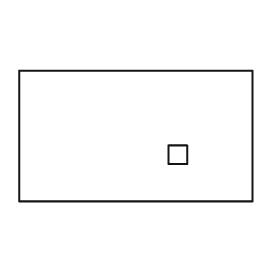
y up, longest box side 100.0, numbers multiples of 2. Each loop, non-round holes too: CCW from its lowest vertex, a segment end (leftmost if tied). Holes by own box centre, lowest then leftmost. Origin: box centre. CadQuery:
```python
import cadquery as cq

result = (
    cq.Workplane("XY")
    .moveTo(-50.0, -28.0)
    .lineTo(50.0, -28.0)
    .lineTo(50.0, 28.0)
    .lineTo(-50.0, 28.0)
    .close()
    .moveTo(14.0, -12.0)
    .lineTo(22.0, -12.0)
    .lineTo(22.0, -4.0)
    .lineTo(14.0, -4.0)
    .close()
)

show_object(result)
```